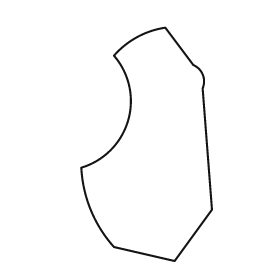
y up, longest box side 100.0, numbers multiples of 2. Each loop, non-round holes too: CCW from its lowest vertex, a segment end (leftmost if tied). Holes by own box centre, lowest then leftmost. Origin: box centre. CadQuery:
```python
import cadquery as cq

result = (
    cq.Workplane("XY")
    .moveTo(12.0, -50.0)
    .lineTo(28.0, -28.0)
    .lineTo(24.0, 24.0)
    .threePointArc((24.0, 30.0), (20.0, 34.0))
    .lineTo(8.0, 50.0)
    .threePointArc((-4.0, 46.0), (-14.0, 38.0))
    .threePointArc((-8.0, 10.0), (-28.0, -10.0))
    .threePointArc((-24.0, -28.0), (-14.0, -44.0))
    .close()
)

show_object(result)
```